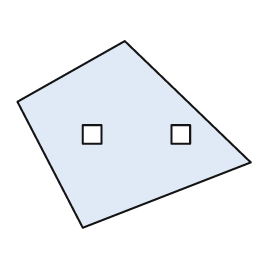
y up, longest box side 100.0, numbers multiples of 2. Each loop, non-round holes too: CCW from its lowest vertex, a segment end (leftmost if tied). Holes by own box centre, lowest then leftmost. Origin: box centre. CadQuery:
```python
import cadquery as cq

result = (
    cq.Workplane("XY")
    .moveTo(-22.0, -40.0)
    .lineTo(50.0, -12.0)
    .lineTo(-4.0, 40.0)
    .lineTo(-50.0, 14.0)
    .close()
    .moveTo(-22.0, -4.0)
    .lineTo(-14.0, -4.0)
    .lineTo(-14.0, 4.0)
    .lineTo(-22.0, 4.0)
    .close()
    .moveTo(16.0, -4.0)
    .lineTo(24.0, -4.0)
    .lineTo(24.0, 4.0)
    .lineTo(16.0, 4.0)
    .close()
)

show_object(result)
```